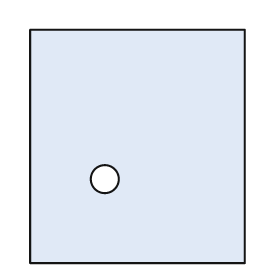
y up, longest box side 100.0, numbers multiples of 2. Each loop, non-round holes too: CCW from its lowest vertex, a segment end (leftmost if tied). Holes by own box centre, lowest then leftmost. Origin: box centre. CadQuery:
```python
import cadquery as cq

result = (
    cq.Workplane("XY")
    .moveTo(-46.0, -50.0)
    .lineTo(46.0, -50.0)
    .lineTo(46.0, 50.0)
    .lineTo(-46.0, 50.0)
    .close()
    .moveTo(-14.0, -14.0)
    .circle(6.0)
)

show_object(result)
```